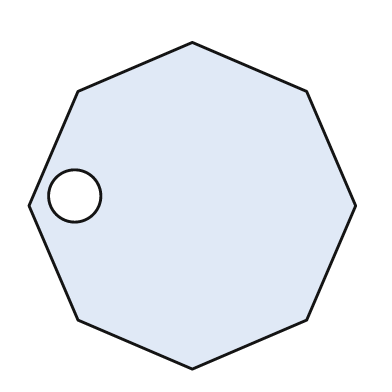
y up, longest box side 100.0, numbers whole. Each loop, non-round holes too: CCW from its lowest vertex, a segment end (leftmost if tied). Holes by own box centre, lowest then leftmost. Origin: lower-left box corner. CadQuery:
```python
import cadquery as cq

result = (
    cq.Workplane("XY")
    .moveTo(50.0, 0.0)
    .lineTo(85.0, 15.0)
    .lineTo(100.0, 50.0)
    .lineTo(85.0, 85.0)
    .lineTo(50.0, 100.0)
    .lineTo(15.0, 85.0)
    .lineTo(0.0, 50.0)
    .lineTo(15.0, 15.0)
    .close()
    .moveTo(14.0, 53.0)
    .circle(8.0)
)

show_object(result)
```